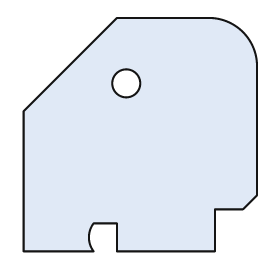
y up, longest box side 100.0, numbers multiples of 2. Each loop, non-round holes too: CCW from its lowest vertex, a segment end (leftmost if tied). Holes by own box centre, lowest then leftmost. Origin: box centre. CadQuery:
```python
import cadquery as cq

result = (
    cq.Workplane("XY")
    .moveTo(-50.0, -50.0)
    .lineTo(-20.0, -50.0)
    .threePointArc((-22.0, -44.0), (-20.0, -38.0))
    .lineTo(-10.0, -38.0)
    .lineTo(-10.0, -50.0)
    .lineTo(32.0, -50.0)
    .lineTo(32.0, -32.0)
    .lineTo(44.0, -32.0)
    .lineTo(50.0, -26.0)
    .lineTo(50.0, 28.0)
    .threePointArc((44.0, 44.0), (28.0, 50.0))
    .lineTo(-10.0, 50.0)
    .lineTo(-50.0, 10.0)
    .close()
    .moveTo(-6.0, 22.0)
    .circle(6.0)
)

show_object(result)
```